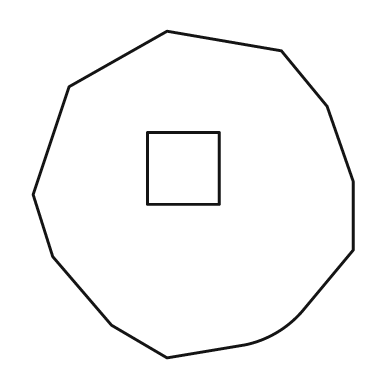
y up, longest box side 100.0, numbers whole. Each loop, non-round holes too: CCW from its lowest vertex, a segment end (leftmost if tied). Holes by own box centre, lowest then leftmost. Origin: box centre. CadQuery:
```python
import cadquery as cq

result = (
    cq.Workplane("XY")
    .moveTo(-8.0, -50.0)
    .lineTo(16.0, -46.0)
    .threePointArc((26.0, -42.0), (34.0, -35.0))
    .lineTo(49.0, -17.0)
    .lineTo(49.0, 4.0)
    .lineTo(41.0, 27.0)
    .lineTo(27.0, 44.0)
    .lineTo(-8.0, 50.0)
    .lineTo(-38.0, 33.0)
    .lineTo(-49.0, 0.0)
    .lineTo(-43.0, -19.0)
    .lineTo(-25.0, -40.0)
    .close()
    .moveTo(-14.0, -3.0)
    .lineTo(8.0, -3.0)
    .lineTo(8.0, 19.0)
    .lineTo(-14.0, 19.0)
    .close()
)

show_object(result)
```